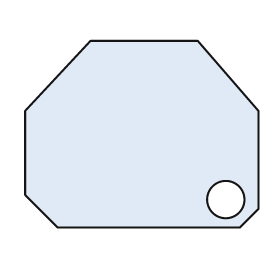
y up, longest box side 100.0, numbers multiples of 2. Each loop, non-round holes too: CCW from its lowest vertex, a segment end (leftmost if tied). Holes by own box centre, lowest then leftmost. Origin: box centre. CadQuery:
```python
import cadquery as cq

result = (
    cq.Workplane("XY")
    .moveTo(-36.0, -40.0)
    .lineTo(42.0, -40.0)
    .lineTo(50.0, -32.0)
    .lineTo(50.0, 10.0)
    .lineTo(24.0, 40.0)
    .lineTo(-22.0, 40.0)
    .lineTo(-50.0, 10.0)
    .lineTo(-50.0, -26.0)
    .close()
    .moveTo(36.0, -28.0)
    .circle(8.0)
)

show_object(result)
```